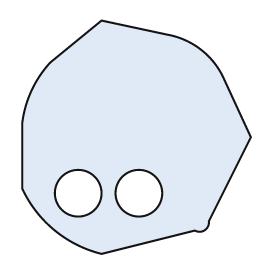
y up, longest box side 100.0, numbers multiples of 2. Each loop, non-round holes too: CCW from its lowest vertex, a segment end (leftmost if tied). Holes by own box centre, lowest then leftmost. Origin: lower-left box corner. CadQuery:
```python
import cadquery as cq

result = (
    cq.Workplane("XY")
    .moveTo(34.0, 0.0)
    .lineTo(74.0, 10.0)
    .threePointArc((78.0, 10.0), (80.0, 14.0))
    .lineTo(98.0, 50.0)
    .lineTo(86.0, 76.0)
    .threePointArc((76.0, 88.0), (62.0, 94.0))
    .lineTo(34.0, 100.0)
    .lineTo(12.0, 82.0)
    .threePointArc((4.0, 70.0), (0.0, 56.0))
    .lineTo(0.0, 28.0)
    .threePointArc((14.0, 10.0), (34.0, 0.0))
    .close()
    .moveTo(24.0, 26.0)
    .circle(10.0)
    .moveTo(50.0, 26.0)
    .circle(10.0)
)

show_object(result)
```